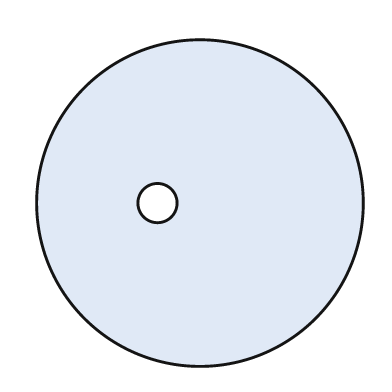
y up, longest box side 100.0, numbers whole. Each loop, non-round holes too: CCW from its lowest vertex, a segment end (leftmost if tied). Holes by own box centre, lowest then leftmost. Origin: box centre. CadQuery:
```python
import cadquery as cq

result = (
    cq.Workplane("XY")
    .moveTo(0.0, 0.0)
    .circle(50.0)
    .moveTo(-13.0, 0.0)
    .circle(6.0)
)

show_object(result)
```